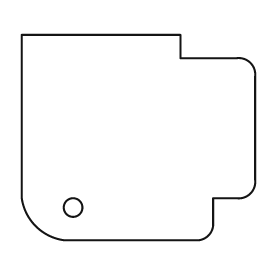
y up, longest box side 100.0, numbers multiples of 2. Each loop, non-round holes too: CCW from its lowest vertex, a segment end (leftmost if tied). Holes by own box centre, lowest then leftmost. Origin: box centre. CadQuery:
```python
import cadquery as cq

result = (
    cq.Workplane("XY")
    .moveTo(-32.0, -44.0)
    .lineTo(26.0, -44.0)
    .threePointArc((30.0, -42.0), (32.0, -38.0))
    .lineTo(32.0, -26.0)
    .lineTo(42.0, -26.0)
    .threePointArc((48.0, -24.0), (50.0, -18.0))
    .lineTo(50.0, 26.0)
    .threePointArc((48.0, 32.0), (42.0, 34.0))
    .lineTo(18.0, 34.0)
    .lineTo(18.0, 44.0)
    .lineTo(-50.0, 44.0)
    .lineTo(-50.0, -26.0)
    .threePointArc((-44.0, -38.0), (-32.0, -44.0))
    .close()
    .moveTo(-28.0, -30.0)
    .circle(4.0)
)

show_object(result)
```